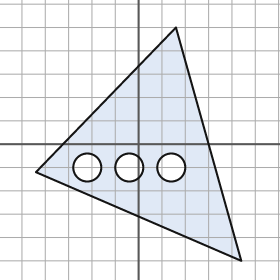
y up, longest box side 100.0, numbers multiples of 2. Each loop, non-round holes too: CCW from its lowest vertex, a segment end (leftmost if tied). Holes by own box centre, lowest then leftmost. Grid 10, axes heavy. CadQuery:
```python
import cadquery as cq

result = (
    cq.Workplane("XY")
    .moveTo(44.0, -50.0)
    .lineTo(16.0, 50.0)
    .lineTo(-44.0, -12.0)
    .close()
    .moveTo(-22.0, -10.0)
    .circle(6.0)
    .moveTo(-4.0, -10.0)
    .circle(6.0)
    .moveTo(14.0, -10.0)
    .circle(6.0)
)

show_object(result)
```